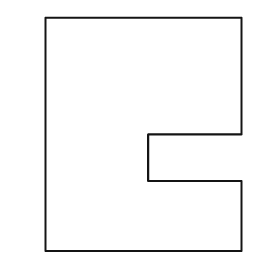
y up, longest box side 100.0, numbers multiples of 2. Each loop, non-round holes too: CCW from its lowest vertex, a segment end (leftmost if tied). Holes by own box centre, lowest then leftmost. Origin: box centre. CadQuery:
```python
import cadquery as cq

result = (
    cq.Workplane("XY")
    .moveTo(-42.0, -50.0)
    .lineTo(42.0, -50.0)
    .lineTo(42.0, -20.0)
    .lineTo(2.0, -20.0)
    .lineTo(2.0, 0.0)
    .lineTo(42.0, 0.0)
    .lineTo(42.0, 50.0)
    .lineTo(-42.0, 50.0)
    .close()
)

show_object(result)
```